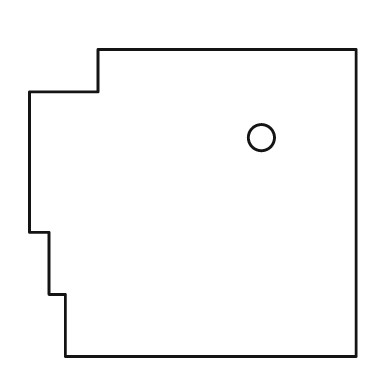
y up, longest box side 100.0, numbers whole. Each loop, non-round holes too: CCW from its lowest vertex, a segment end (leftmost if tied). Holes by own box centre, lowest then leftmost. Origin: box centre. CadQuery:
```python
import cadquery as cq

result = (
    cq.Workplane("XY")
    .moveTo(-39.0, -47.0)
    .lineTo(50.0, -47.0)
    .lineTo(50.0, 47.0)
    .lineTo(-29.0, 47.0)
    .lineTo(-29.0, 34.0)
    .lineTo(-50.0, 34.0)
    .lineTo(-50.0, -9.0)
    .lineTo(-44.0, -9.0)
    .lineTo(-44.0, -28.0)
    .lineTo(-39.0, -28.0)
    .close()
    .moveTo(21.0, 20.0)
    .circle(4.0)
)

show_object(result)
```